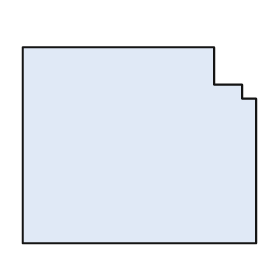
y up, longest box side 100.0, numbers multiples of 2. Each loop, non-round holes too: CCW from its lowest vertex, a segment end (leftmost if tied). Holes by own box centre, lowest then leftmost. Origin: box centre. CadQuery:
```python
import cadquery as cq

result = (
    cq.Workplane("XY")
    .moveTo(-50.0, -42.0)
    .lineTo(50.0, -42.0)
    .lineTo(50.0, 20.0)
    .lineTo(44.0, 20.0)
    .lineTo(44.0, 26.0)
    .lineTo(32.0, 26.0)
    .lineTo(32.0, 42.0)
    .lineTo(-50.0, 42.0)
    .close()
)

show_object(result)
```